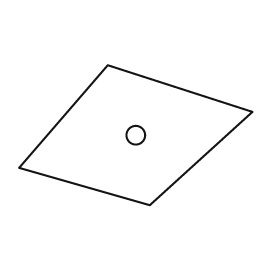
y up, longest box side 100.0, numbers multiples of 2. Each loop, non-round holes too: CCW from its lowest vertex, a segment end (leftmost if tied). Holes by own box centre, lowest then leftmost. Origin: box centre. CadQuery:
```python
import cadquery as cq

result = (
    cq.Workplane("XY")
    .moveTo(6.0, -30.0)
    .lineTo(50.0, 10.0)
    .lineTo(-12.0, 30.0)
    .lineTo(-50.0, -14.0)
    .close()
    .moveTo(0.0, 0.0)
    .circle(4.0)
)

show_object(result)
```